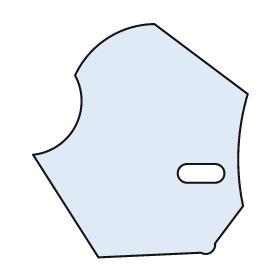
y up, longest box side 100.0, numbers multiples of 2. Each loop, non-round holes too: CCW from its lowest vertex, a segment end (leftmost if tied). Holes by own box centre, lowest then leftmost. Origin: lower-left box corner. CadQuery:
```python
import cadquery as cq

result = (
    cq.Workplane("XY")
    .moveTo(28.0, 0.0)
    .lineTo(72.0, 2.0)
    .threePointArc((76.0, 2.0), (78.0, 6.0))
    .lineTo(90.0, 22.0)
    .threePointArc((88.0, 46.0), (92.0, 70.0))
    .lineTo(52.0, 100.0)
    .threePointArc((32.0, 94.0), (18.0, 78.0))
    .threePointArc((18.0, 56.0), (0.0, 44.0))
    .close()
    .moveTo(66.0, 32.0)
    .lineTo(78.0, 32.0)
    .threePointArc((82.0, 36.0), (78.0, 40.0))
    .lineTo(66.0, 40.0)
    .threePointArc((62.0, 36.0), (66.0, 32.0))
    .close()
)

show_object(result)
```